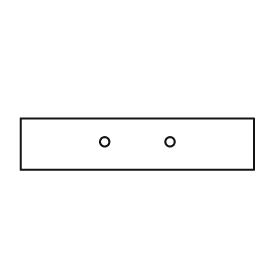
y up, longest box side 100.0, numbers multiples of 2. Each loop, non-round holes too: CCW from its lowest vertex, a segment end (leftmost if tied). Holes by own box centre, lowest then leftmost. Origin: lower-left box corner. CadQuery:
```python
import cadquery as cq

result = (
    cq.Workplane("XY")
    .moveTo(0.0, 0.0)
    .lineTo(100.0, 0.0)
    .lineTo(100.0, 22.0)
    .lineTo(0.0, 22.0)
    .close()
    .moveTo(36.0, 12.0)
    .circle(2.0)
    .moveTo(64.0, 12.0)
    .circle(2.0)
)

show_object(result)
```